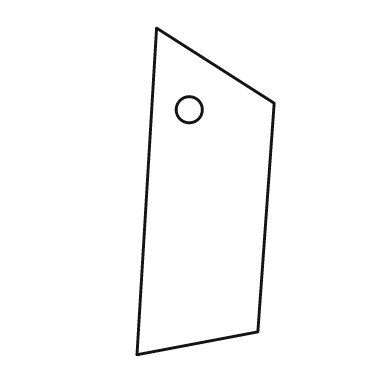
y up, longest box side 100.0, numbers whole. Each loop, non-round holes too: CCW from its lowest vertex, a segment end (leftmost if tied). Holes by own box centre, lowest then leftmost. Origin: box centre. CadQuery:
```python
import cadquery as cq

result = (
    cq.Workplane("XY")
    .moveTo(-21.0, -50.0)
    .lineTo(16.0, -43.0)
    .lineTo(21.0, 27.0)
    .lineTo(-15.0, 50.0)
    .close()
    .moveTo(-5.0, 25.0)
    .circle(4.0)
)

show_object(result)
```